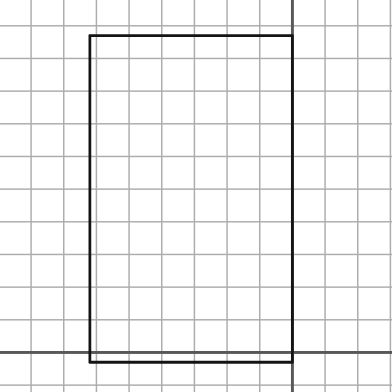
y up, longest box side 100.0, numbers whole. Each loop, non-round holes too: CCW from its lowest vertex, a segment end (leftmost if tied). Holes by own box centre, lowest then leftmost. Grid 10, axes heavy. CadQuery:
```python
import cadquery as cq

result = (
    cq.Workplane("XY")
    .moveTo(-62.0, -3.0)
    .lineTo(0.0, -3.0)
    .lineTo(0.0, 97.0)
    .lineTo(-62.0, 97.0)
    .close()
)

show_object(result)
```